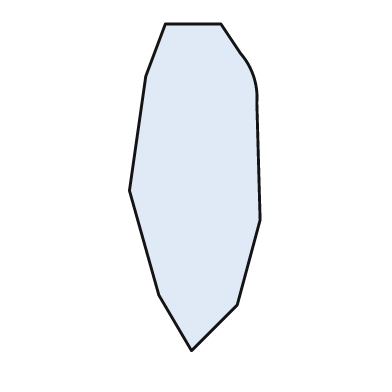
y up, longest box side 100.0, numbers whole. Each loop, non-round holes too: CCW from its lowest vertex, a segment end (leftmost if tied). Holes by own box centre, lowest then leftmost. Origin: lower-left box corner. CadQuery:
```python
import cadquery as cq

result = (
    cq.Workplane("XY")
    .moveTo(19.0, 0.0)
    .lineTo(33.0, 14.0)
    .lineTo(40.0, 40.0)
    .lineTo(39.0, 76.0)
    .threePointArc((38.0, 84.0), (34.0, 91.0))
    .lineTo(28.0, 100.0)
    .lineTo(11.0, 100.0)
    .lineTo(5.0, 84.0)
    .lineTo(0.0, 49.0)
    .lineTo(9.0, 17.0)
    .close()
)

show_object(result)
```